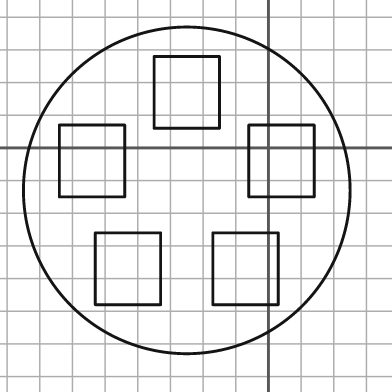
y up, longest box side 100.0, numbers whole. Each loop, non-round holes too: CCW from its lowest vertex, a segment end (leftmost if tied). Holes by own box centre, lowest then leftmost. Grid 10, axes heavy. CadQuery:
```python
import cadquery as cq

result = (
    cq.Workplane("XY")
    .moveTo(-25.0, -13.0)
    .circle(50.0)
    .moveTo(-53.0, -48.0)
    .lineTo(-33.0, -48.0)
    .lineTo(-33.0, -26.0)
    .lineTo(-53.0, -26.0)
    .close()
    .moveTo(-17.0, -48.0)
    .lineTo(3.0, -48.0)
    .lineTo(3.0, -26.0)
    .lineTo(-17.0, -26.0)
    .close()
    .moveTo(-64.0, -15.0)
    .lineTo(-44.0, -15.0)
    .lineTo(-44.0, 7.0)
    .lineTo(-64.0, 7.0)
    .close()
    .moveTo(-6.0, -15.0)
    .lineTo(14.0, -15.0)
    .lineTo(14.0, 7.0)
    .lineTo(-6.0, 7.0)
    .close()
    .moveTo(-35.0, 6.0)
    .lineTo(-15.0, 6.0)
    .lineTo(-15.0, 28.0)
    .lineTo(-35.0, 28.0)
    .close()
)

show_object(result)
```